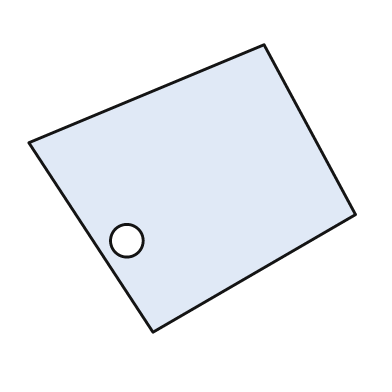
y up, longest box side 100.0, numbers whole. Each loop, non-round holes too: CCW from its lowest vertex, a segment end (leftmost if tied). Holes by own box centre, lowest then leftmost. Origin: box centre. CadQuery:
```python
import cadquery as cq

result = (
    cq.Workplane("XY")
    .moveTo(-12.0, -44.0)
    .lineTo(50.0, -8.0)
    .lineTo(22.0, 44.0)
    .lineTo(-50.0, 14.0)
    .close()
    .moveTo(-20.0, -16.0)
    .circle(5.0)
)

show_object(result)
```